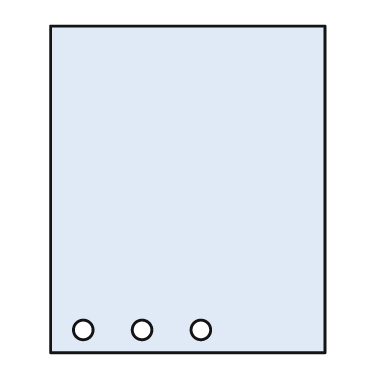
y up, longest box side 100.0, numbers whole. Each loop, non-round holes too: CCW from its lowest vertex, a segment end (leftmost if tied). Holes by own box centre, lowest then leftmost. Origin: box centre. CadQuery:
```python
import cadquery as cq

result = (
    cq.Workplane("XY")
    .moveTo(-42.0, -50.0)
    .lineTo(42.0, -50.0)
    .lineTo(42.0, 50.0)
    .lineTo(-42.0, 50.0)
    .close()
    .moveTo(-32.0, -43.0)
    .circle(3.0)
    .moveTo(-14.0, -43.0)
    .circle(3.0)
    .moveTo(4.0, -43.0)
    .circle(3.0)
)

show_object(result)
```